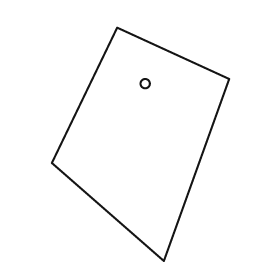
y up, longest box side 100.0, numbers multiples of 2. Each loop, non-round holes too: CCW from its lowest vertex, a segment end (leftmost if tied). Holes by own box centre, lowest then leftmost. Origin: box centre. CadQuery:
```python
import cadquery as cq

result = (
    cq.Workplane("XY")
    .moveTo(10.0, -50.0)
    .lineTo(38.0, 28.0)
    .lineTo(-10.0, 50.0)
    .lineTo(-38.0, -8.0)
    .close()
    .moveTo(2.0, 26.0)
    .circle(2.0)
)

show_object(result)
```